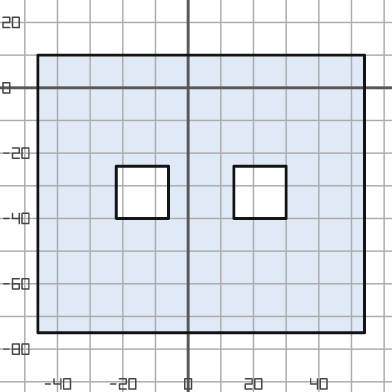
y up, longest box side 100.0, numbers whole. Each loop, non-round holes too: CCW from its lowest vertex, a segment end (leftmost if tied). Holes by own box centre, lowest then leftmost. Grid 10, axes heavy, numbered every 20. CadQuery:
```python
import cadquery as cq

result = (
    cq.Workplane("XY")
    .moveTo(-46.0, -75.0)
    .lineTo(54.0, -75.0)
    .lineTo(54.0, 10.0)
    .lineTo(-46.0, 10.0)
    .close()
    .moveTo(-22.0, -40.0)
    .lineTo(-6.0, -40.0)
    .lineTo(-6.0, -24.0)
    .lineTo(-22.0, -24.0)
    .close()
    .moveTo(14.0, -40.0)
    .lineTo(30.0, -40.0)
    .lineTo(30.0, -24.0)
    .lineTo(14.0, -24.0)
    .close()
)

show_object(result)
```